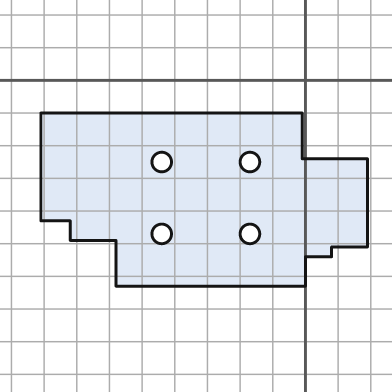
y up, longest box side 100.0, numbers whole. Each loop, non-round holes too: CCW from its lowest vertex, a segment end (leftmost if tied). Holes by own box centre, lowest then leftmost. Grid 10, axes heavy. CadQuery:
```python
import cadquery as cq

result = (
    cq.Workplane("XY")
    .moveTo(-58.0, -63.0)
    .lineTo(0.0, -63.0)
    .lineTo(0.0, -54.0)
    .lineTo(8.0, -54.0)
    .lineTo(8.0, -51.0)
    .lineTo(19.0, -51.0)
    .lineTo(19.0, -24.0)
    .lineTo(-1.0, -24.0)
    .lineTo(-1.0, -10.0)
    .lineTo(-81.0, -10.0)
    .lineTo(-81.0, -43.0)
    .lineTo(-72.0, -43.0)
    .lineTo(-72.0, -49.0)
    .lineTo(-58.0, -49.0)
    .close()
    .moveTo(-44.0, -47.0)
    .circle(3.0)
    .moveTo(-17.0, -47.0)
    .circle(3.0)
    .moveTo(-44.0, -25.0)
    .circle(3.0)
    .moveTo(-17.0, -25.0)
    .circle(3.0)
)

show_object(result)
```